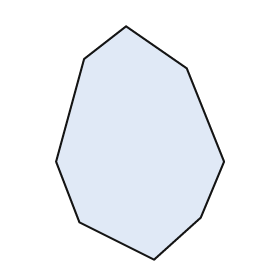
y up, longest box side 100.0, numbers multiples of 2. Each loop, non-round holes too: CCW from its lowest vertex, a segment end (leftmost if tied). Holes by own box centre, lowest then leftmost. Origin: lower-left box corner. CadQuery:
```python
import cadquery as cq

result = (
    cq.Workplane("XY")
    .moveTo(42.0, 0.0)
    .lineTo(62.0, 18.0)
    .lineTo(72.0, 42.0)
    .lineTo(56.0, 82.0)
    .lineTo(30.0, 100.0)
    .lineTo(12.0, 86.0)
    .lineTo(0.0, 42.0)
    .lineTo(10.0, 16.0)
    .close()
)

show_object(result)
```